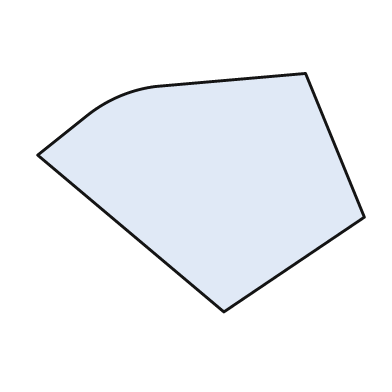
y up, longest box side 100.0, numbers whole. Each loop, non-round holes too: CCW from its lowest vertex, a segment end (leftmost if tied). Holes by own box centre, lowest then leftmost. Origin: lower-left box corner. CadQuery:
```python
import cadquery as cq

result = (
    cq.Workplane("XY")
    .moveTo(57.0, 0.0)
    .lineTo(100.0, 29.0)
    .lineTo(82.0, 73.0)
    .lineTo(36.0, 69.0)
    .threePointArc((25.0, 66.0), (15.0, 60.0))
    .lineTo(0.0, 48.0)
    .close()
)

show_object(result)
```